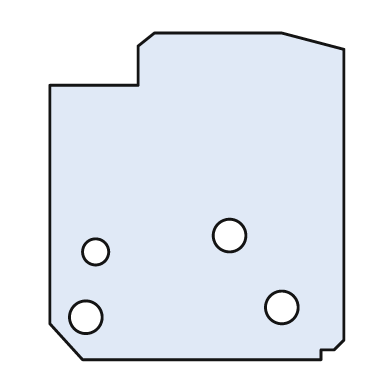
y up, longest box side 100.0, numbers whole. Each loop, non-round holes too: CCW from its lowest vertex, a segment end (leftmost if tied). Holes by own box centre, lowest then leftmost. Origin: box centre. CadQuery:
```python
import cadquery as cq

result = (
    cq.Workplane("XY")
    .moveTo(-35.0, -50.0)
    .lineTo(38.0, -50.0)
    .lineTo(38.0, -47.0)
    .lineTo(42.0, -47.0)
    .lineTo(45.0, -44.0)
    .lineTo(45.0, 45.0)
    .lineTo(26.0, 50.0)
    .lineTo(-13.0, 50.0)
    .lineTo(-18.0, 46.0)
    .lineTo(-18.0, 34.0)
    .lineTo(-45.0, 34.0)
    .lineTo(-45.0, -39.0)
    .close()
    .moveTo(-34.0, -37.0)
    .circle(5.0)
    .moveTo(26.0, -34.0)
    .circle(5.0)
    .moveTo(-31.0, -17.0)
    .circle(4.0)
    .moveTo(10.0, -12.0)
    .circle(5.0)
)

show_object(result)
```